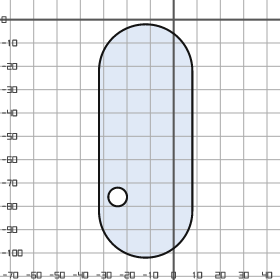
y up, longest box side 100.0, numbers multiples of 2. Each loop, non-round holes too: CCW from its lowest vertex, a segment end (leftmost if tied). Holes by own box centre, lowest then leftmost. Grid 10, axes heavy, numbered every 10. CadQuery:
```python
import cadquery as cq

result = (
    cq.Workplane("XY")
    .moveTo(-32.0, -82.0)
    .threePointArc((-12.0, -102.0), (8.0, -82.0))
    .lineTo(8.0, -22.0)
    .threePointArc((-12.0, -2.0), (-32.0, -22.0))
    .close()
    .moveTo(-24.0, -76.0)
    .circle(4.0)
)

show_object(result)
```